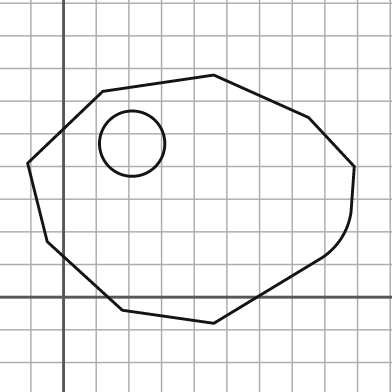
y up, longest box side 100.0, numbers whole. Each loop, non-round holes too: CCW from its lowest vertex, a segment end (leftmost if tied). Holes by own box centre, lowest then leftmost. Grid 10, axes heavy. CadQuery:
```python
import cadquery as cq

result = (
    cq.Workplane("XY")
    .moveTo(46.0, -8.0)
    .lineTo(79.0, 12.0)
    .threePointArc((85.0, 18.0), (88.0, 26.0))
    .lineTo(89.0, 40.0)
    .lineTo(75.0, 55.0)
    .lineTo(46.0, 68.0)
    .lineTo(12.0, 63.0)
    .lineTo(-11.0, 41.0)
    .lineTo(-5.0, 17.0)
    .lineTo(18.0, -4.0)
    .close()
    .moveTo(21.0, 47.0)
    .circle(10.0)
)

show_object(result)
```